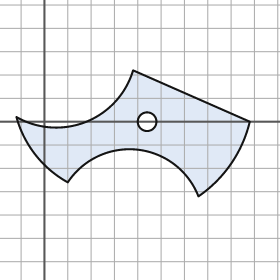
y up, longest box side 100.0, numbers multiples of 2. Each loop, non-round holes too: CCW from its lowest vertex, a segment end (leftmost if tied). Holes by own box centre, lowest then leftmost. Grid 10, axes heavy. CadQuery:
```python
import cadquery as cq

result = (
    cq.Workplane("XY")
    .moveTo(66.0, -32.0)
    .threePointArc((80.0, -18.0), (88.0, 0.0))
    .lineTo(38.0, 22.0)
    .threePointArc((18.0, 0.0), (-12.0, 2.0))
    .threePointArc((-4.0, -14.0), (10.0, -26.0))
    .threePointArc((40.0, -12.0), (66.0, -32.0))
    .close()
    .moveTo(44.0, 0.0)
    .circle(4.0)
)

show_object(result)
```